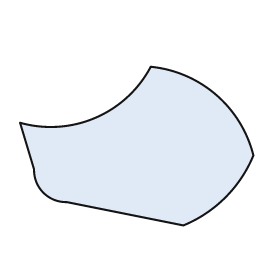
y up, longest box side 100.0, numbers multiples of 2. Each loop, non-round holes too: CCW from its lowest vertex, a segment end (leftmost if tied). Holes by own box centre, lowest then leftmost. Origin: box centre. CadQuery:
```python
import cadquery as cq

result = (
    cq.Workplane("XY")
    .moveTo(20.0, -34.0)
    .threePointArc((38.0, -22.0), (50.0, -4.0))
    .threePointArc((34.0, 22.0), (6.0, 34.0))
    .threePointArc((-18.0, 12.0), (-50.0, 10.0))
    .lineTo(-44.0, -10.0)
    .threePointArc((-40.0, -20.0), (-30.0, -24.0))
    .close()
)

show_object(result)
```